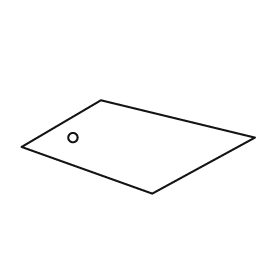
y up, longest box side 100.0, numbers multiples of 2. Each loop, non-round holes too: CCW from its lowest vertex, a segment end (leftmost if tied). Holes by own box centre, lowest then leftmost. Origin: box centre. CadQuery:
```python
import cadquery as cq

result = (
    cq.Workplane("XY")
    .moveTo(6.0, -20.0)
    .lineTo(50.0, 4.0)
    .lineTo(-16.0, 20.0)
    .lineTo(-50.0, 0.0)
    .close()
    .moveTo(-28.0, 4.0)
    .circle(2.0)
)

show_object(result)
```